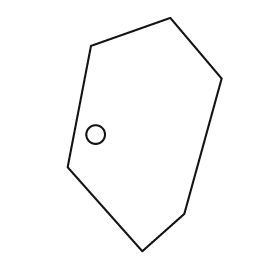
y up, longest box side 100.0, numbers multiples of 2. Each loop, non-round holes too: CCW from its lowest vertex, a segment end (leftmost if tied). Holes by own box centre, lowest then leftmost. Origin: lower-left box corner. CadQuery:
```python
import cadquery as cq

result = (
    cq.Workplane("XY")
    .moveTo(32.0, 0.0)
    .lineTo(50.0, 16.0)
    .lineTo(66.0, 74.0)
    .lineTo(44.0, 100.0)
    .lineTo(10.0, 88.0)
    .lineTo(0.0, 36.0)
    .close()
    .moveTo(12.0, 50.0)
    .circle(4.0)
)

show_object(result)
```